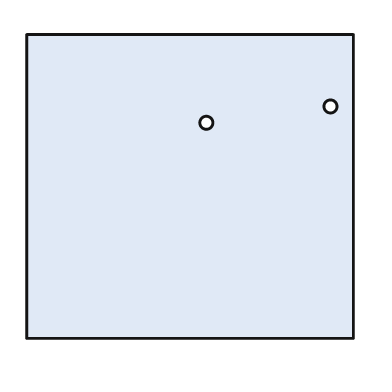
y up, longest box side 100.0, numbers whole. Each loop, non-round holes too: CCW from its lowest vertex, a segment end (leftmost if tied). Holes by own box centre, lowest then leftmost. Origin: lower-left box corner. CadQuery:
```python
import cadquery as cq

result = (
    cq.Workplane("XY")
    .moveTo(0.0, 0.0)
    .lineTo(100.0, 0.0)
    .lineTo(100.0, 93.0)
    .lineTo(0.0, 93.0)
    .close()
    .moveTo(55.0, 66.0)
    .circle(2.0)
    .moveTo(93.0, 71.0)
    .circle(2.0)
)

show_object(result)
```